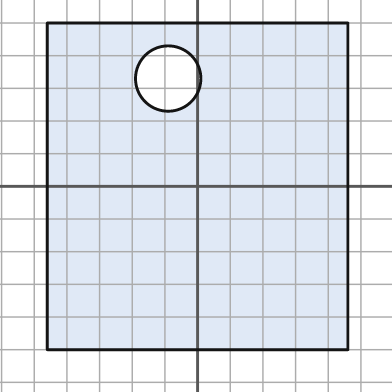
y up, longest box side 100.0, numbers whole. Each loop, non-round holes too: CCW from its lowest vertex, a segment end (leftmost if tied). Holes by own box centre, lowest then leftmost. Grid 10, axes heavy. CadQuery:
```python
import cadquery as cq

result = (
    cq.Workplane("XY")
    .moveTo(-46.0, -50.0)
    .lineTo(46.0, -50.0)
    .lineTo(46.0, 50.0)
    .lineTo(-46.0, 50.0)
    .close()
    .moveTo(-9.0, 33.0)
    .circle(10.0)
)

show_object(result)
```